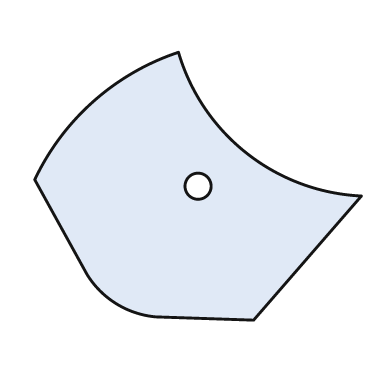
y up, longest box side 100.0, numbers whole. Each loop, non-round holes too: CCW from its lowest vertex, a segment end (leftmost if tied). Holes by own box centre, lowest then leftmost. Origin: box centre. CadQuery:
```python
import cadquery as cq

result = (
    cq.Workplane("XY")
    .moveTo(17.0, -41.0)
    .lineTo(50.0, -3.0)
    .threePointArc((15.0, 10.0), (-6.0, 41.0))
    .threePointArc((-32.0, 26.0), (-50.0, 2.0))
    .lineTo(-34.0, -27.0)
    .threePointArc((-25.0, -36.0), (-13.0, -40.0))
    .close()
    .moveTo(0.0, 0.0)
    .circle(4.0)
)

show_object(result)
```